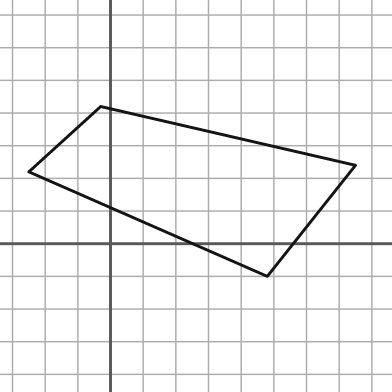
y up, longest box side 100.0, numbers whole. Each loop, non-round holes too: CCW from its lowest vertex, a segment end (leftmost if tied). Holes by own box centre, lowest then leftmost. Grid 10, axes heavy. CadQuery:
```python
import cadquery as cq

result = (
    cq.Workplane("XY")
    .moveTo(48.0, -10.0)
    .lineTo(75.0, 24.0)
    .lineTo(-3.0, 42.0)
    .lineTo(-25.0, 22.0)
    .close()
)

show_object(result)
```